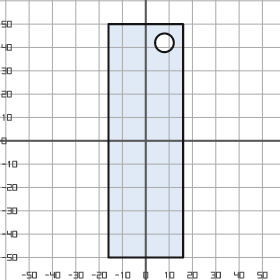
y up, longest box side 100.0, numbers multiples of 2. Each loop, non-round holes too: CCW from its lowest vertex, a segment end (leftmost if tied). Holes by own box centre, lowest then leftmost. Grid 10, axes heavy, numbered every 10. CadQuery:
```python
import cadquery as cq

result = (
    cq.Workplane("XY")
    .moveTo(-16.0, -50.0)
    .lineTo(16.0, -50.0)
    .lineTo(16.0, 50.0)
    .lineTo(-16.0, 50.0)
    .close()
    .moveTo(8.0, 42.0)
    .circle(4.0)
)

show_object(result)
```